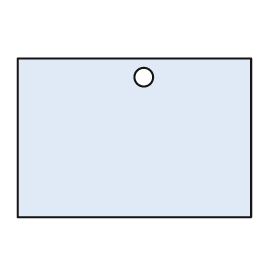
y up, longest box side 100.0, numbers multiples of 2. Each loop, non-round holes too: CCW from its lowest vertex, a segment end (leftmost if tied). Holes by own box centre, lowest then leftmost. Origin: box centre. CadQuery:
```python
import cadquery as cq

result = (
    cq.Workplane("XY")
    .moveTo(-50.0, -34.0)
    .lineTo(50.0, -34.0)
    .lineTo(50.0, 34.0)
    .lineTo(-50.0, 34.0)
    .close()
    .moveTo(4.0, 26.0)
    .circle(4.0)
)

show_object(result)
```